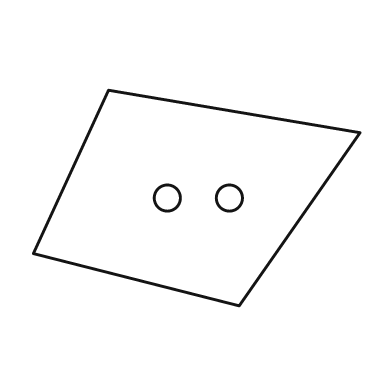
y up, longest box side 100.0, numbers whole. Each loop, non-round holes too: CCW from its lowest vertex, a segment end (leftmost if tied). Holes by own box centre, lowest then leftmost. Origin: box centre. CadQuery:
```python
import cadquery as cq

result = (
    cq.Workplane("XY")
    .moveTo(13.0, -33.0)
    .lineTo(50.0, 20.0)
    .lineTo(-27.0, 33.0)
    .lineTo(-50.0, -17.0)
    .close()
    .moveTo(-9.0, 0.0)
    .circle(4.0)
    .moveTo(10.0, 0.0)
    .circle(4.0)
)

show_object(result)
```